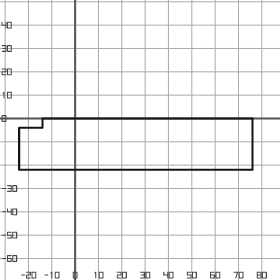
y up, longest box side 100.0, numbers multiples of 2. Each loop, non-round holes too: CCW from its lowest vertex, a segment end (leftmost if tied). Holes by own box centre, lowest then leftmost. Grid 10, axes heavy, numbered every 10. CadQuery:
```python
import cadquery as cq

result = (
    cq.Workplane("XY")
    .moveTo(-24.0, -22.0)
    .lineTo(76.0, -22.0)
    .lineTo(76.0, 0.0)
    .lineTo(-14.0, 0.0)
    .lineTo(-14.0, -4.0)
    .lineTo(-24.0, -4.0)
    .close()
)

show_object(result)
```